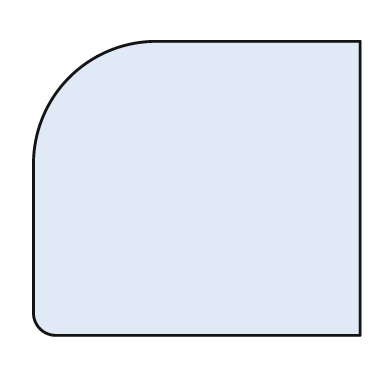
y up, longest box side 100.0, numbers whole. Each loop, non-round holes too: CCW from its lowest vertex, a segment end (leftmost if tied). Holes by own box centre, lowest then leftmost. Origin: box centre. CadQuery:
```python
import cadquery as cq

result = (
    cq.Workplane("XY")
    .moveTo(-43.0, -45.0)
    .lineTo(50.0, -45.0)
    .lineTo(50.0, 45.0)
    .lineTo(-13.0, 45.0)
    .threePointArc((-39.0, 34.0), (-50.0, 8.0))
    .lineTo(-50.0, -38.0)
    .threePointArc((-48.0, -43.0), (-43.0, -45.0))
    .close()
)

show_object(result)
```